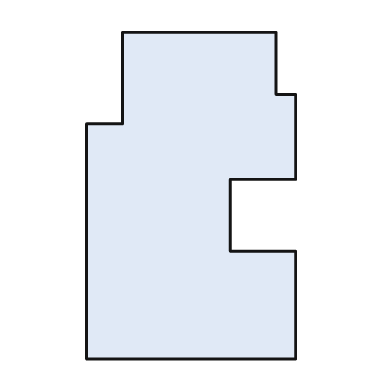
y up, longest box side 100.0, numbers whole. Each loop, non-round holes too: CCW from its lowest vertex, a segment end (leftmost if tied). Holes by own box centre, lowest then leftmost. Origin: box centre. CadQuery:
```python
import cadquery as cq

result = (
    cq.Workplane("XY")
    .moveTo(-32.0, -50.0)
    .lineTo(32.0, -50.0)
    .lineTo(32.0, -17.0)
    .lineTo(12.0, -17.0)
    .lineTo(12.0, 5.0)
    .lineTo(32.0, 5.0)
    .lineTo(32.0, 31.0)
    .lineTo(26.0, 31.0)
    .lineTo(26.0, 50.0)
    .lineTo(-21.0, 50.0)
    .lineTo(-21.0, 22.0)
    .lineTo(-32.0, 22.0)
    .close()
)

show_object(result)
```